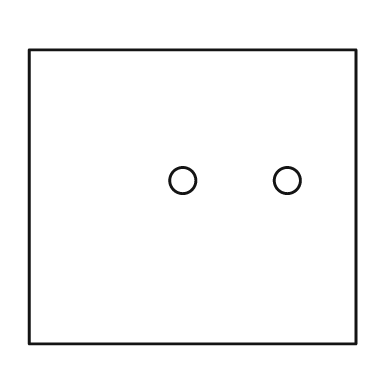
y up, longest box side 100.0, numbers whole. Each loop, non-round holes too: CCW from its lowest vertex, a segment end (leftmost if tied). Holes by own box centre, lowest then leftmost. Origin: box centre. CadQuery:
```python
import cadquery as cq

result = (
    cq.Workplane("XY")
    .moveTo(-50.0, -45.0)
    .lineTo(50.0, -45.0)
    .lineTo(50.0, 45.0)
    .lineTo(-50.0, 45.0)
    .close()
    .moveTo(-3.0, 5.0)
    .circle(4.0)
    .moveTo(29.0, 5.0)
    .circle(4.0)
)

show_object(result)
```